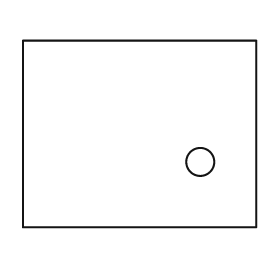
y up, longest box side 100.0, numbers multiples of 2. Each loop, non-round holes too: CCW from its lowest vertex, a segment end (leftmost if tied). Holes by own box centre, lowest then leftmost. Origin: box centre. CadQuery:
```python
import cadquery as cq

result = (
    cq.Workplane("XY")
    .moveTo(-50.0, -40.0)
    .lineTo(50.0, -40.0)
    .lineTo(50.0, 40.0)
    .lineTo(-50.0, 40.0)
    .close()
    .moveTo(26.0, -12.0)
    .circle(6.0)
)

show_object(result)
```